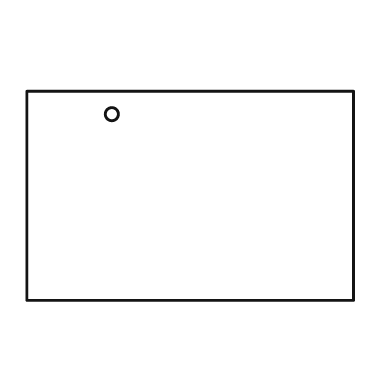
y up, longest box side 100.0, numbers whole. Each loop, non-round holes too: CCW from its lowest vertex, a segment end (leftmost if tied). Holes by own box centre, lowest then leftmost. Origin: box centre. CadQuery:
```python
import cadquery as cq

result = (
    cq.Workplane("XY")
    .moveTo(-50.0, -32.0)
    .lineTo(50.0, -32.0)
    .lineTo(50.0, 32.0)
    .lineTo(-50.0, 32.0)
    .close()
    .moveTo(-24.0, 25.0)
    .circle(2.0)
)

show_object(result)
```